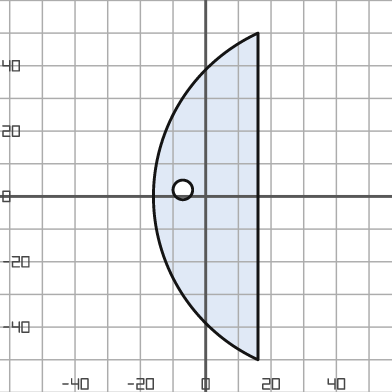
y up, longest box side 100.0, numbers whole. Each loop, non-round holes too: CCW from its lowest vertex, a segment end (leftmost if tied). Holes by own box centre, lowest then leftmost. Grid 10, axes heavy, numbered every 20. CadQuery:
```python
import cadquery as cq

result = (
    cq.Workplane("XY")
    .moveTo(16.0, -50.0)
    .lineTo(16.0, 50.0)
    .threePointArc((-16.0, 0.0), (16.0, -50.0))
    .close()
    .moveTo(-7.0, 2.0)
    .circle(3.0)
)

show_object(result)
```